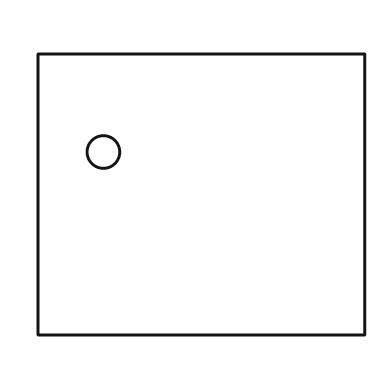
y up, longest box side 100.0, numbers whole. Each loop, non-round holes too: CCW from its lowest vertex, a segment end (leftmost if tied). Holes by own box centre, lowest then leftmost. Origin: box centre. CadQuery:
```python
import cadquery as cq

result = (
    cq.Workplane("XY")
    .moveTo(-50.0, -43.0)
    .lineTo(50.0, -43.0)
    .lineTo(50.0, 43.0)
    .lineTo(-50.0, 43.0)
    .close()
    .moveTo(-30.0, 13.0)
    .circle(5.0)
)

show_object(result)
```